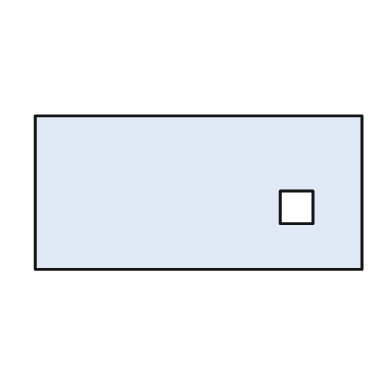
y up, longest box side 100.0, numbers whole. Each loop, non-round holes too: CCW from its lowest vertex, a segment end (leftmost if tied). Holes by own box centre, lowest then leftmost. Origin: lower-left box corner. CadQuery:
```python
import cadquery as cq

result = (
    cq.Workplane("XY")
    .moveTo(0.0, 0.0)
    .lineTo(100.0, 0.0)
    .lineTo(100.0, 47.0)
    .lineTo(0.0, 47.0)
    .close()
    .moveTo(75.0, 14.0)
    .lineTo(85.0, 14.0)
    .lineTo(85.0, 24.0)
    .lineTo(75.0, 24.0)
    .close()
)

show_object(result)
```